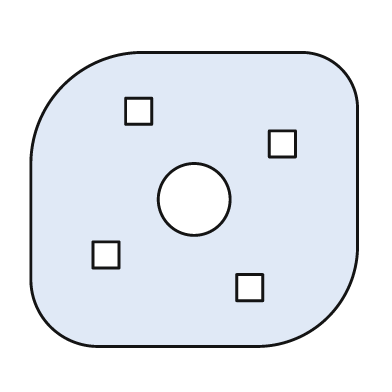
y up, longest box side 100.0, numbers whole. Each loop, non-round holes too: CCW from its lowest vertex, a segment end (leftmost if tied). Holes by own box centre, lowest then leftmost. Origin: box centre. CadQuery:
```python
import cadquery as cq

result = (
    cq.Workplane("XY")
    .moveTo(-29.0, -45.0)
    .lineTo(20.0, -45.0)
    .threePointArc((41.0, -36.0), (50.0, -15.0))
    .lineTo(50.0, 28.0)
    .threePointArc((45.0, 40.0), (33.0, 45.0))
    .lineTo(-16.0, 45.0)
    .threePointArc((-40.0, 35.0), (-50.0, 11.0))
    .lineTo(-50.0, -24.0)
    .threePointArc((-44.0, -39.0), (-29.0, -45.0))
    .close()
    .moveTo(13.0, -31.0)
    .lineTo(21.0, -31.0)
    .lineTo(21.0, -23.0)
    .lineTo(13.0, -23.0)
    .close()
    .moveTo(-31.0, -21.0)
    .lineTo(-23.0, -21.0)
    .lineTo(-23.0, -13.0)
    .lineTo(-31.0, -13.0)
    .close()
    .moveTo(0.0, 0.0)
    .circle(11.0)
    .moveTo(23.0, 13.0)
    .lineTo(31.0, 13.0)
    .lineTo(31.0, 21.0)
    .lineTo(23.0, 21.0)
    .close()
    .moveTo(-21.0, 23.0)
    .lineTo(-13.0, 23.0)
    .lineTo(-13.0, 31.0)
    .lineTo(-21.0, 31.0)
    .close()
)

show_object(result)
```